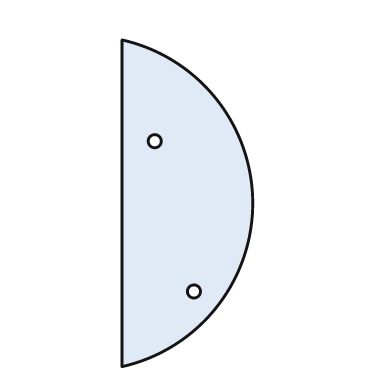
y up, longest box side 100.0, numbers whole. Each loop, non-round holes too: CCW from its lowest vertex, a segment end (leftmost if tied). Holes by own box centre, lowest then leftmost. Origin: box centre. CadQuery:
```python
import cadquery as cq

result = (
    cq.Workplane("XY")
    .moveTo(-20.0, -50.0)
    .threePointArc((20.0, 0.0), (-20.0, 50.0))
    .close()
    .moveTo(2.0, -27.0)
    .circle(2.0)
    .moveTo(-10.0, 19.0)
    .circle(2.0)
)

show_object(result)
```